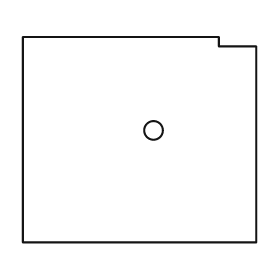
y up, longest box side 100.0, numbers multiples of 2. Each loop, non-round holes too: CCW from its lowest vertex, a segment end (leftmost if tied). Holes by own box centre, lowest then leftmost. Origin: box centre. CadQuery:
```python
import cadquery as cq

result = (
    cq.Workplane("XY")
    .moveTo(-50.0, -44.0)
    .lineTo(50.0, -44.0)
    .lineTo(50.0, 40.0)
    .lineTo(34.0, 40.0)
    .lineTo(34.0, 44.0)
    .lineTo(-50.0, 44.0)
    .close()
    .moveTo(6.0, 4.0)
    .circle(4.0)
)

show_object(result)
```